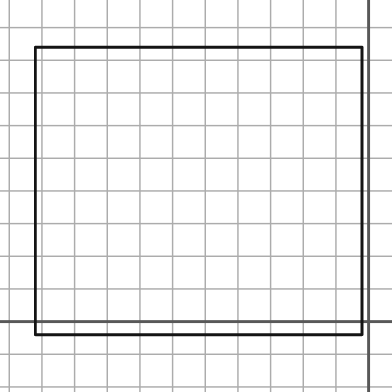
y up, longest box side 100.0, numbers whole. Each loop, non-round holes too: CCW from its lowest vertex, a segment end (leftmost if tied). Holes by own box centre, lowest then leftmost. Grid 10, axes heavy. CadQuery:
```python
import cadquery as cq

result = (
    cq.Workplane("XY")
    .moveTo(-102.0, -4.0)
    .lineTo(-2.0, -4.0)
    .lineTo(-2.0, 84.0)
    .lineTo(-102.0, 84.0)
    .close()
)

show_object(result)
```